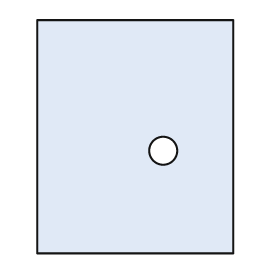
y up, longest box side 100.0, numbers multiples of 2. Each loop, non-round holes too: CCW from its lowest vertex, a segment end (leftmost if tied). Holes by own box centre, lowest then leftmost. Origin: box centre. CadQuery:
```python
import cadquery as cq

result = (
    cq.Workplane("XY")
    .moveTo(-42.0, -50.0)
    .lineTo(42.0, -50.0)
    .lineTo(42.0, 50.0)
    .lineTo(-42.0, 50.0)
    .close()
    .moveTo(12.0, -6.0)
    .circle(6.0)
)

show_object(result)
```